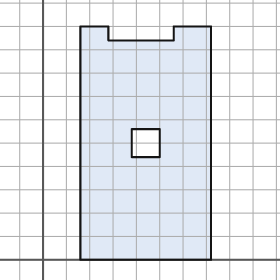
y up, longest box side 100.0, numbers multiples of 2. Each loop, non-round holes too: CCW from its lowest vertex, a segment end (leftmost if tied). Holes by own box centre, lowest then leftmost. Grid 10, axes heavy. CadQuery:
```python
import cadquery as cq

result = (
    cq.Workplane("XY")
    .moveTo(16.0, 0.0)
    .lineTo(72.0, 0.0)
    .lineTo(72.0, 100.0)
    .lineTo(56.0, 100.0)
    .lineTo(56.0, 94.0)
    .lineTo(28.0, 94.0)
    .lineTo(28.0, 100.0)
    .lineTo(16.0, 100.0)
    .close()
    .moveTo(38.0, 44.0)
    .lineTo(50.0, 44.0)
    .lineTo(50.0, 56.0)
    .lineTo(38.0, 56.0)
    .close()
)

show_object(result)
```